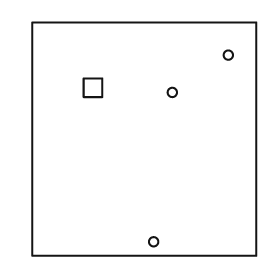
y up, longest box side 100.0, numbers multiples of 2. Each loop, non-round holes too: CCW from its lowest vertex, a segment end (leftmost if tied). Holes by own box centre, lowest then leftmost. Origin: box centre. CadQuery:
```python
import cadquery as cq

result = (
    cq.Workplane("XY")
    .moveTo(-48.0, -50.0)
    .lineTo(48.0, -50.0)
    .lineTo(48.0, 50.0)
    .lineTo(-48.0, 50.0)
    .close()
    .moveTo(4.0, -44.0)
    .circle(2.0)
    .moveTo(12.0, 20.0)
    .circle(2.0)
    .moveTo(-26.0, 18.0)
    .lineTo(-18.0, 18.0)
    .lineTo(-18.0, 26.0)
    .lineTo(-26.0, 26.0)
    .close()
    .moveTo(36.0, 36.0)
    .circle(2.0)
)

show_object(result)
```